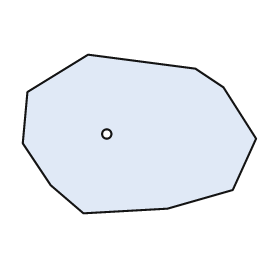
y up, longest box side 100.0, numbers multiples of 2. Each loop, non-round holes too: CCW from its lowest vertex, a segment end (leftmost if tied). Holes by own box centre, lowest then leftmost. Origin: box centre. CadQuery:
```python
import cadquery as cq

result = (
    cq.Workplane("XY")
    .moveTo(-24.0, -34.0)
    .lineTo(12.0, -32.0)
    .lineTo(40.0, -24.0)
    .lineTo(50.0, -2.0)
    .lineTo(36.0, 20.0)
    .lineTo(24.0, 28.0)
    .lineTo(-22.0, 34.0)
    .lineTo(-48.0, 18.0)
    .lineTo(-50.0, -4.0)
    .lineTo(-38.0, -22.0)
    .close()
    .moveTo(-14.0, 0.0)
    .circle(2.0)
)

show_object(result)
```